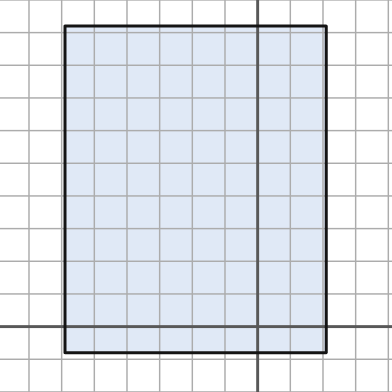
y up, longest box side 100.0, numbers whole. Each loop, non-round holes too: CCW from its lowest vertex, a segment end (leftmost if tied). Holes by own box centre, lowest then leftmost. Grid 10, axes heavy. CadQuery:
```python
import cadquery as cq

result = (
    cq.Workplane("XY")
    .moveTo(-59.0, -8.0)
    .lineTo(21.0, -8.0)
    .lineTo(21.0, 92.0)
    .lineTo(-59.0, 92.0)
    .close()
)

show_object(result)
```